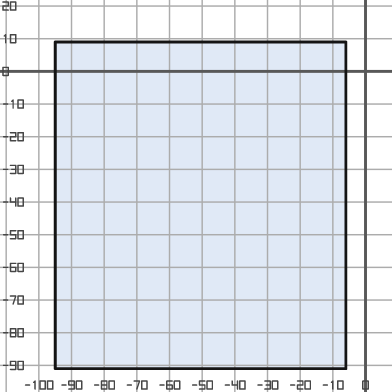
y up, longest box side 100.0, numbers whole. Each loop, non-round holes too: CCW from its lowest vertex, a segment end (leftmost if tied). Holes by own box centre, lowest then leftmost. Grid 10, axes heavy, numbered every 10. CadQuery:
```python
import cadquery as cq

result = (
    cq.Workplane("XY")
    .moveTo(-95.0, -91.0)
    .lineTo(-6.0, -91.0)
    .lineTo(-6.0, 9.0)
    .lineTo(-95.0, 9.0)
    .close()
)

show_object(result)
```